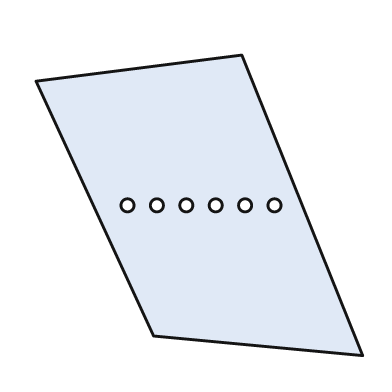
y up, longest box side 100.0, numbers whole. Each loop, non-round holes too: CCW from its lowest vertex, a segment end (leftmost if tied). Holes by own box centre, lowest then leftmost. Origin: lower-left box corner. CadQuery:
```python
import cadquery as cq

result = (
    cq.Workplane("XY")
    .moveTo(100.0, 0.0)
    .lineTo(63.0, 92.0)
    .lineTo(0.0, 84.0)
    .lineTo(36.0, 6.0)
    .close()
    .moveTo(28.0, 46.0)
    .circle(2.0)
    .moveTo(37.0, 46.0)
    .circle(2.0)
    .moveTo(46.0, 46.0)
    .circle(2.0)
    .moveTo(55.0, 46.0)
    .circle(2.0)
    .moveTo(64.0, 46.0)
    .circle(2.0)
    .moveTo(73.0, 46.0)
    .circle(2.0)
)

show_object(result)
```